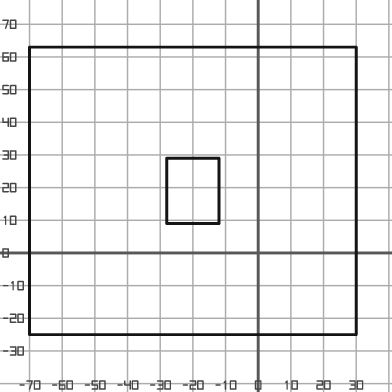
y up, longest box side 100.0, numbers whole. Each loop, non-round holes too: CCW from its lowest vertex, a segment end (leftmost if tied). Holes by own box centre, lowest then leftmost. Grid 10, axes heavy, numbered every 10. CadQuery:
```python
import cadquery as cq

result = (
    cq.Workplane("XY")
    .moveTo(-70.0, -25.0)
    .lineTo(30.0, -25.0)
    .lineTo(30.0, 63.0)
    .lineTo(-70.0, 63.0)
    .close()
    .moveTo(-28.0, 9.0)
    .lineTo(-12.0, 9.0)
    .lineTo(-12.0, 29.0)
    .lineTo(-28.0, 29.0)
    .close()
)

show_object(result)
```